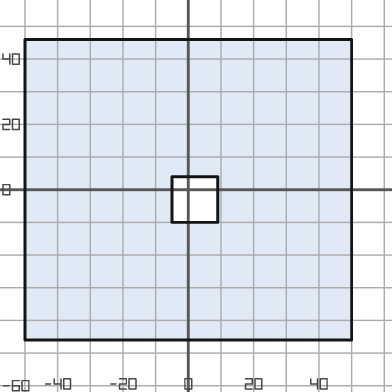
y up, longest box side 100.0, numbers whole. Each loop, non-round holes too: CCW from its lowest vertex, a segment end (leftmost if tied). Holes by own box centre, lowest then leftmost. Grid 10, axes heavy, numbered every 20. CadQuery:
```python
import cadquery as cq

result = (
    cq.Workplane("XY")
    .moveTo(-50.0, -46.0)
    .lineTo(50.0, -46.0)
    .lineTo(50.0, 46.0)
    .lineTo(-50.0, 46.0)
    .close()
    .moveTo(-5.0, -10.0)
    .lineTo(9.0, -10.0)
    .lineTo(9.0, 4.0)
    .lineTo(-5.0, 4.0)
    .close()
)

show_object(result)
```